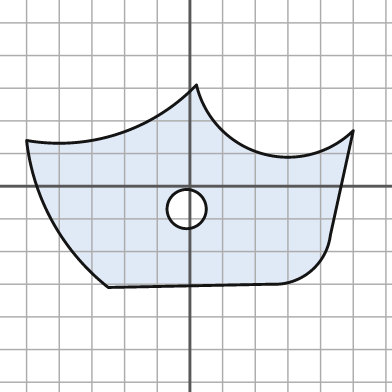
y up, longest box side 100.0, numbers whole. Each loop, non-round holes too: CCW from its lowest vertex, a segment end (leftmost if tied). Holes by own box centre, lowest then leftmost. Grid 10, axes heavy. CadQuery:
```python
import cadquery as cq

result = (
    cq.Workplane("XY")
    .moveTo(-25.0, -31.0)
    .lineTo(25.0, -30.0)
    .threePointArc((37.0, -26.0), (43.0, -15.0))
    .lineTo(50.0, 17.0)
    .threePointArc((22.0, 10.0), (2.0, 31.0))
    .threePointArc((-22.0, 16.0), (-50.0, 14.0))
    .threePointArc((-42.0, -11.0), (-25.0, -31.0))
    .close()
    .moveTo(-1.0, -7.0)
    .circle(6.0)
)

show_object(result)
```